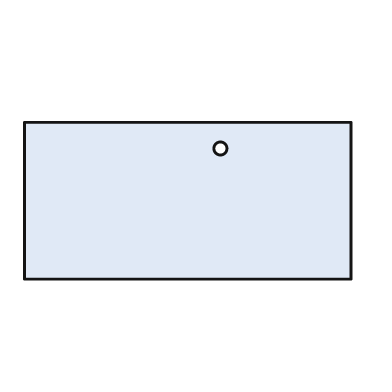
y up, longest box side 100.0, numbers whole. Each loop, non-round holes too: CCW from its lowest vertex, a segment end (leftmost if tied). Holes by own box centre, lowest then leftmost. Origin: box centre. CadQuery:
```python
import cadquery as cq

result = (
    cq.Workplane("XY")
    .moveTo(-50.0, -24.0)
    .lineTo(50.0, -24.0)
    .lineTo(50.0, 24.0)
    .lineTo(-50.0, 24.0)
    .close()
    .moveTo(10.0, 16.0)
    .circle(2.0)
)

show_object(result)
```